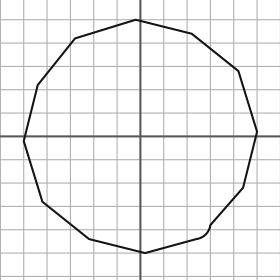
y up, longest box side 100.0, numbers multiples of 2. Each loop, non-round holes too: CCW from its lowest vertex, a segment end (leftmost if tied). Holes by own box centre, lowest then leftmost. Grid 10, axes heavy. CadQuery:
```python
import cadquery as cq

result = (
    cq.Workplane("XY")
    .moveTo(2.0, -50.0)
    .lineTo(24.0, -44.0)
    .threePointArc((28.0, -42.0), (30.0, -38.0))
    .lineTo(44.0, -22.0)
    .lineTo(50.0, 2.0)
    .lineTo(42.0, 28.0)
    .lineTo(22.0, 44.0)
    .lineTo(-2.0, 50.0)
    .lineTo(-28.0, 42.0)
    .lineTo(-44.0, 22.0)
    .lineTo(-50.0, -2.0)
    .lineTo(-42.0, -28.0)
    .lineTo(-22.0, -44.0)
    .close()
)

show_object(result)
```